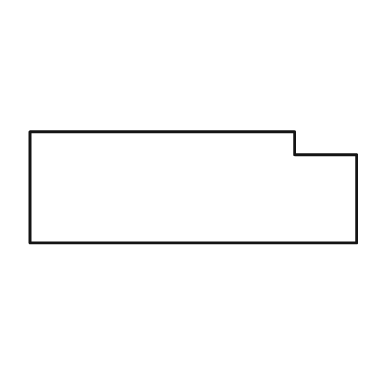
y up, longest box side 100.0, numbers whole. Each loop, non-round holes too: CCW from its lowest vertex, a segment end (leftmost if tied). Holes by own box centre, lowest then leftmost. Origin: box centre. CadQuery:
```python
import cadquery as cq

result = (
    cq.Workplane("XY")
    .moveTo(-50.0, -17.0)
    .lineTo(50.0, -17.0)
    .lineTo(50.0, 10.0)
    .lineTo(31.0, 10.0)
    .lineTo(31.0, 17.0)
    .lineTo(-50.0, 17.0)
    .close()
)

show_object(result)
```